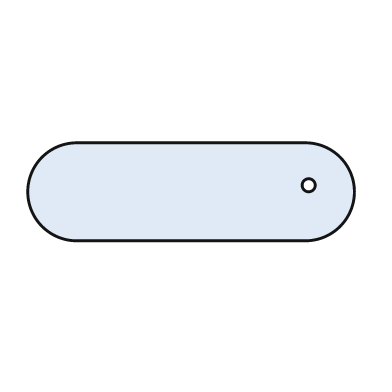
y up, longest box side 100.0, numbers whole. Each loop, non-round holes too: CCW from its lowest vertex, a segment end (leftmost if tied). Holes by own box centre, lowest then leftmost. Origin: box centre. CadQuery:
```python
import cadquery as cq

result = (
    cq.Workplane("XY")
    .moveTo(-35.0, -15.0)
    .lineTo(35.0, -15.0)
    .threePointArc((50.0, 0.0), (35.0, 15.0))
    .lineTo(-35.0, 15.0)
    .threePointArc((-50.0, 0.0), (-35.0, -15.0))
    .close()
    .moveTo(36.0, 2.0)
    .circle(2.0)
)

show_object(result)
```